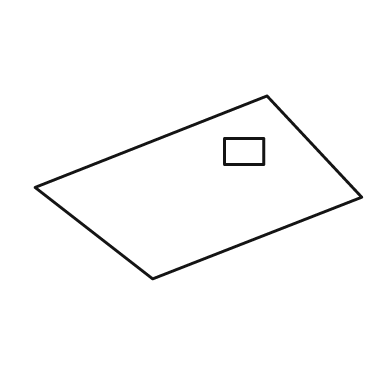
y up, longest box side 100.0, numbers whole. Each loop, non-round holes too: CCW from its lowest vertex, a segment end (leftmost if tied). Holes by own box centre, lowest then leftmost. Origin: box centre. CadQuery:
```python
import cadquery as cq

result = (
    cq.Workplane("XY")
    .moveTo(-14.0, -28.0)
    .lineTo(50.0, -3.0)
    .lineTo(21.0, 28.0)
    .lineTo(-50.0, 0.0)
    .close()
    .moveTo(8.0, 7.0)
    .lineTo(20.0, 7.0)
    .lineTo(20.0, 15.0)
    .lineTo(8.0, 15.0)
    .close()
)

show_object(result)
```